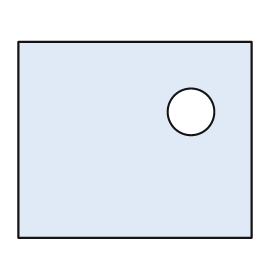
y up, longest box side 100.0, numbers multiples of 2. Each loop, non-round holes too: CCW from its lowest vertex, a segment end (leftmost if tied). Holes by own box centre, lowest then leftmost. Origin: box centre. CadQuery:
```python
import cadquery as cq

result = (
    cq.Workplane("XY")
    .moveTo(-50.0, -42.0)
    .lineTo(50.0, -42.0)
    .lineTo(50.0, 42.0)
    .lineTo(-50.0, 42.0)
    .close()
    .moveTo(24.0, 12.0)
    .circle(10.0)
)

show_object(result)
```